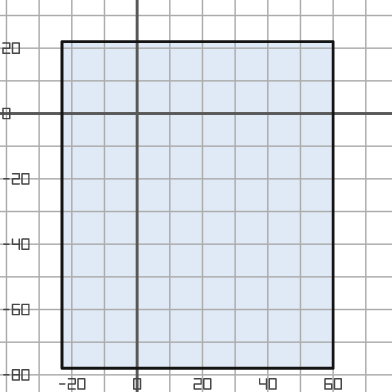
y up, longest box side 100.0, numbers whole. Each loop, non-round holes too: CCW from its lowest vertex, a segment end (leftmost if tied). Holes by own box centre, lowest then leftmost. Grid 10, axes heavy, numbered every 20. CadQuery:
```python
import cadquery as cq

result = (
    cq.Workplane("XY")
    .moveTo(-23.0, -78.0)
    .lineTo(60.0, -78.0)
    .lineTo(60.0, 22.0)
    .lineTo(-23.0, 22.0)
    .close()
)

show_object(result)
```